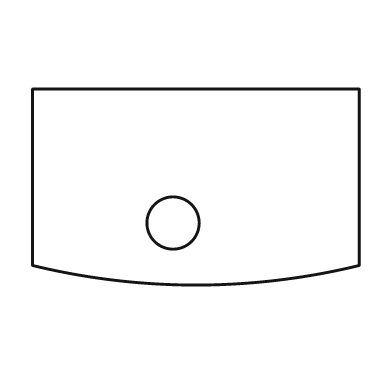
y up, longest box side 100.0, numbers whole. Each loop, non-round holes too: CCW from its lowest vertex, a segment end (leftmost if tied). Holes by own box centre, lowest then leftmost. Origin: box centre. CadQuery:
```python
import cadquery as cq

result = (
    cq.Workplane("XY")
    .moveTo(-50.0, -24.0)
    .threePointArc((0.0, -30.0), (50.0, -24.0))
    .lineTo(50.0, 30.0)
    .lineTo(-50.0, 30.0)
    .close()
    .moveTo(-7.0, -11.0)
    .circle(8.0)
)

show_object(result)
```